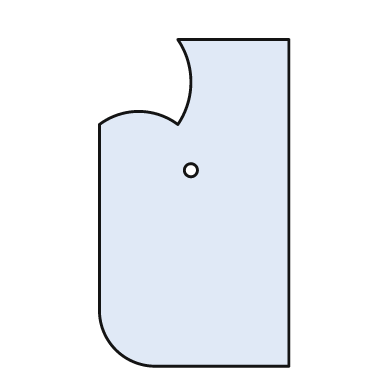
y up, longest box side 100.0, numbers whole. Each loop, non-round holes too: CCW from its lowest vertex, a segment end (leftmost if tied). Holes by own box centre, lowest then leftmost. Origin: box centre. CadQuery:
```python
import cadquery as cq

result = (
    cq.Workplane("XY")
    .moveTo(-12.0, -50.0)
    .lineTo(29.0, -50.0)
    .lineTo(29.0, 50.0)
    .lineTo(-5.0, 50.0)
    .threePointArc((-1.0, 37.0), (-5.0, 24.0))
    .threePointArc((-17.0, 28.0), (-29.0, 24.0))
    .lineTo(-29.0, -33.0)
    .threePointArc((-24.0, -45.0), (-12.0, -50.0))
    .close()
    .moveTo(-1.0, 10.0)
    .circle(2.0)
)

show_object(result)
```